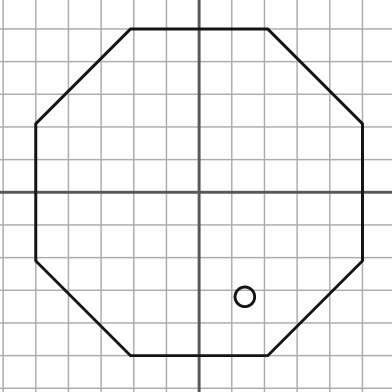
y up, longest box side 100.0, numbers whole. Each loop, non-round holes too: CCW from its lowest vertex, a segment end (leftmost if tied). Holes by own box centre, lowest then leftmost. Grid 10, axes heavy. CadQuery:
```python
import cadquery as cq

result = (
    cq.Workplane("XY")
    .moveTo(-21.0, -50.0)
    .lineTo(21.0, -50.0)
    .lineTo(50.0, -21.0)
    .lineTo(50.0, 21.0)
    .lineTo(21.0, 50.0)
    .lineTo(-21.0, 50.0)
    .lineTo(-50.0, 21.0)
    .lineTo(-50.0, -21.0)
    .close()
    .moveTo(14.0, -32.0)
    .circle(3.0)
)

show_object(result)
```